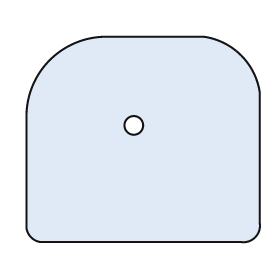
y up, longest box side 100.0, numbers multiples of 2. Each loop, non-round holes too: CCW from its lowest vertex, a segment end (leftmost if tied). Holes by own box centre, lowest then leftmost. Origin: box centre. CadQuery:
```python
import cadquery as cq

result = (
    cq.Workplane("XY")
    .moveTo(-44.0, -44.0)
    .lineTo(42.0, -44.0)
    .threePointArc((48.0, -42.0), (50.0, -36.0))
    .lineTo(50.0, 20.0)
    .threePointArc((42.0, 36.0), (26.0, 44.0))
    .lineTo(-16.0, 44.0)
    .threePointArc((-40.0, 34.0), (-50.0, 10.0))
    .lineTo(-50.0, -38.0)
    .threePointArc((-48.0, -42.0), (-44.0, -44.0))
    .close()
    .moveTo(-4.0, 6.0)
    .circle(4.0)
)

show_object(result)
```